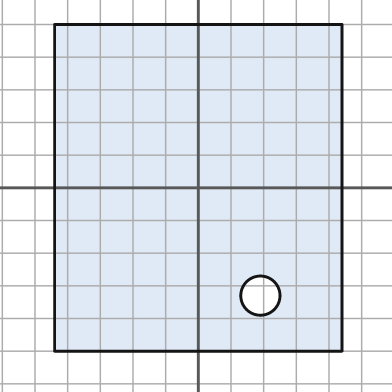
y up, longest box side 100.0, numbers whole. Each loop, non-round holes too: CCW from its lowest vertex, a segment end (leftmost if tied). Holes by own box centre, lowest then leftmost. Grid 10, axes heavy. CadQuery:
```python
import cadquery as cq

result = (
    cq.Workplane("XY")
    .moveTo(-44.0, -50.0)
    .lineTo(44.0, -50.0)
    .lineTo(44.0, 50.0)
    .lineTo(-44.0, 50.0)
    .close()
    .moveTo(19.0, -33.0)
    .circle(6.0)
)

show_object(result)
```